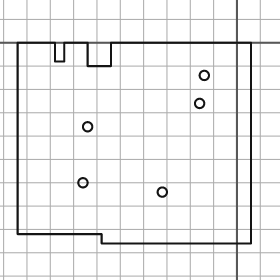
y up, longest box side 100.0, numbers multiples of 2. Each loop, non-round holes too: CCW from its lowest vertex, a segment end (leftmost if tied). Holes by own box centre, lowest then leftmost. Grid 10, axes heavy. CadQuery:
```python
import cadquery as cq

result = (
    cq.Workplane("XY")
    .moveTo(-58.0, -86.0)
    .lineTo(6.0, -86.0)
    .lineTo(6.0, 0.0)
    .lineTo(-54.0, 0.0)
    .lineTo(-54.0, -10.0)
    .lineTo(-64.0, -10.0)
    .lineTo(-64.0, 0.0)
    .lineTo(-74.0, 0.0)
    .lineTo(-74.0, -8.0)
    .lineTo(-78.0, -8.0)
    .lineTo(-78.0, 0.0)
    .lineTo(-94.0, 0.0)
    .lineTo(-94.0, -82.0)
    .lineTo(-58.0, -82.0)
    .close()
    .moveTo(-32.0, -64.0)
    .circle(2.0)
    .moveTo(-66.0, -60.0)
    .circle(2.0)
    .moveTo(-64.0, -36.0)
    .circle(2.0)
    .moveTo(-16.0, -26.0)
    .circle(2.0)
    .moveTo(-14.0, -14.0)
    .circle(2.0)
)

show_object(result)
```